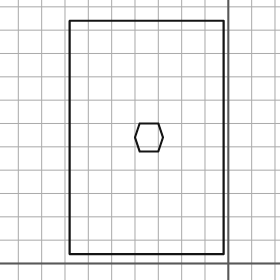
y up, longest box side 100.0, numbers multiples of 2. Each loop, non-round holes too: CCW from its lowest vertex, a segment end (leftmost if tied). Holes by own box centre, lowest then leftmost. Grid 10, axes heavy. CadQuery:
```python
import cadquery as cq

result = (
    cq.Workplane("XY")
    .moveTo(-68.0, 4.0)
    .lineTo(-2.0, 4.0)
    .lineTo(-2.0, 104.0)
    .lineTo(-68.0, 104.0)
    .close()
    .moveTo(-38.0, 48.0)
    .lineTo(-30.0, 48.0)
    .lineTo(-28.0, 54.0)
    .lineTo(-30.0, 60.0)
    .lineTo(-38.0, 60.0)
    .lineTo(-40.0, 54.0)
    .close()
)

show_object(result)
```